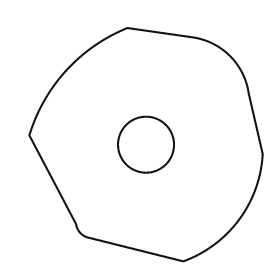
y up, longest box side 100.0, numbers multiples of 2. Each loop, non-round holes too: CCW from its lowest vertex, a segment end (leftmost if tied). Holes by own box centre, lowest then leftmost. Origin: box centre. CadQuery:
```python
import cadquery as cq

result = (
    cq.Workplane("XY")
    .moveTo(16.0, -50.0)
    .threePointArc((40.0, -32.0), (50.0, -4.0))
    .lineTo(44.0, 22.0)
    .threePointArc((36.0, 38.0), (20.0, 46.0))
    .lineTo(-8.0, 50.0)
    .threePointArc((-34.0, 32.0), (-50.0, 4.0))
    .lineTo(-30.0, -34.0)
    .threePointArc((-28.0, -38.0), (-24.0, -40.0))
    .close()
    .moveTo(0.0, 0.0)
    .circle(12.0)
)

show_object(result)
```